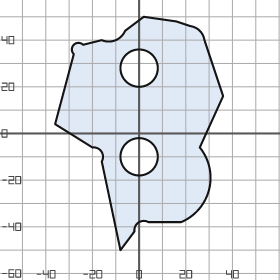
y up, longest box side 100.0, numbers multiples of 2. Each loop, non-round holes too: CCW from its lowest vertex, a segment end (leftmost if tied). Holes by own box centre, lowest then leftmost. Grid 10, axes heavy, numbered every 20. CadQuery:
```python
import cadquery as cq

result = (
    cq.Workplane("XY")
    .moveTo(-8.0, -50.0)
    .lineTo(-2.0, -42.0)
    .threePointArc((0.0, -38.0), (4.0, -38.0))
    .lineTo(18.0, -38.0)
    .threePointArc((30.0, -24.0), (26.0, -6.0))
    .lineTo(36.0, 16.0)
    .lineTo(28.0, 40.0)
    .threePointArc((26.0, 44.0), (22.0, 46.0))
    .lineTo(16.0, 48.0)
    .lineTo(2.0, 50.0)
    .lineTo(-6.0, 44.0)
    .threePointArc((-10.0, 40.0), (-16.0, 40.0))
    .lineTo(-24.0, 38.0)
    .threePointArc((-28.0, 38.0), (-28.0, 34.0))
    .lineTo(-36.0, 4.0)
    .lineTo(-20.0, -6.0)
    .threePointArc((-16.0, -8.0), (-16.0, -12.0))
    .close()
    .moveTo(0.0, -10.0)
    .circle(8.0)
    .moveTo(0.0, 28.0)
    .circle(8.0)
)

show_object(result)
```